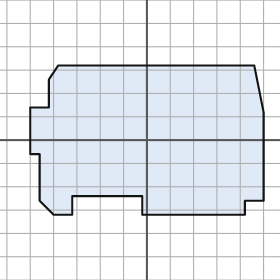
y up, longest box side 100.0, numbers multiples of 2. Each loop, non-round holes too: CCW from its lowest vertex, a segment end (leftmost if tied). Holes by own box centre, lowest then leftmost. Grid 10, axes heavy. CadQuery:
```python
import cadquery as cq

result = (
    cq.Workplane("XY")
    .moveTo(-40.0, -32.0)
    .lineTo(-32.0, -32.0)
    .lineTo(-32.0, -24.0)
    .lineTo(-2.0, -24.0)
    .lineTo(-2.0, -32.0)
    .lineTo(42.0, -32.0)
    .lineTo(42.0, -26.0)
    .lineTo(50.0, -26.0)
    .lineTo(50.0, 12.0)
    .lineTo(46.0, 32.0)
    .lineTo(-38.0, 32.0)
    .lineTo(-42.0, 26.0)
    .lineTo(-42.0, 14.0)
    .lineTo(-50.0, 14.0)
    .lineTo(-50.0, -6.0)
    .lineTo(-46.0, -6.0)
    .lineTo(-46.0, -26.0)
    .close()
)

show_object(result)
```